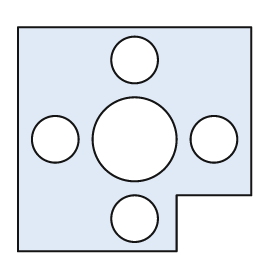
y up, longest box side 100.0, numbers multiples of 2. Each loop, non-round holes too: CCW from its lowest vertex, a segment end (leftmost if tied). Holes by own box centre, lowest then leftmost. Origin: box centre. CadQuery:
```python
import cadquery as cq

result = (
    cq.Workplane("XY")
    .moveTo(-50.0, -48.0)
    .lineTo(18.0, -48.0)
    .lineTo(18.0, -24.0)
    .lineTo(50.0, -24.0)
    .lineTo(50.0, 48.0)
    .lineTo(-50.0, 48.0)
    .close()
    .moveTo(0.0, -34.0)
    .circle(10.0)
    .moveTo(-34.0, 0.0)
    .circle(10.0)
    .moveTo(0.0, 0.0)
    .circle(18.0)
    .moveTo(34.0, 0.0)
    .circle(10.0)
    .moveTo(0.0, 34.0)
    .circle(10.0)
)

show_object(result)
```